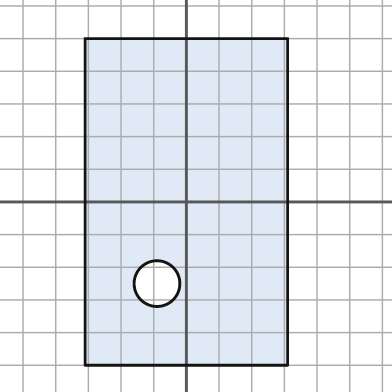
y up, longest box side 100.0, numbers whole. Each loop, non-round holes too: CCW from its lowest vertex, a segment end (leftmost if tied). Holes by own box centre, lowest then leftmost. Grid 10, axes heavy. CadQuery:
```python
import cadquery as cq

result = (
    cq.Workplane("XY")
    .moveTo(-31.0, -50.0)
    .lineTo(31.0, -50.0)
    .lineTo(31.0, 50.0)
    .lineTo(-31.0, 50.0)
    .close()
    .moveTo(-9.0, -25.0)
    .circle(7.0)
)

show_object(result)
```